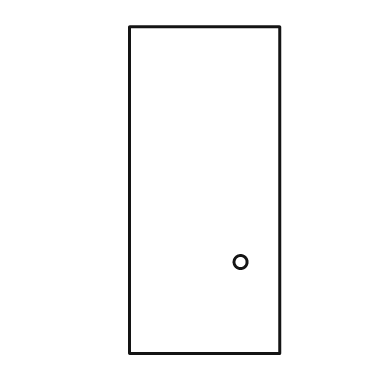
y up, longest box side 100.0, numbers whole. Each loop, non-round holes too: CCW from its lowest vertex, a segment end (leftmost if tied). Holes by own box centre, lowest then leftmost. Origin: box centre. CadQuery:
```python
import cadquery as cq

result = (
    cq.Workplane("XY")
    .moveTo(-23.0, -50.0)
    .lineTo(23.0, -50.0)
    .lineTo(23.0, 50.0)
    .lineTo(-23.0, 50.0)
    .close()
    .moveTo(11.0, -22.0)
    .circle(2.0)
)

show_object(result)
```